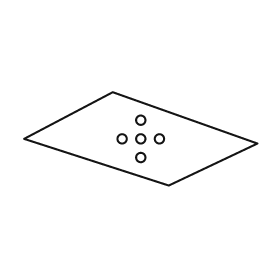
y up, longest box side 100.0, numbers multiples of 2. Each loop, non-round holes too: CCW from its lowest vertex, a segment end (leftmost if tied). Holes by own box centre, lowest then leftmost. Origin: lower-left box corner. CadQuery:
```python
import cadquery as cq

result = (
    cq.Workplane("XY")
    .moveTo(62.0, 0.0)
    .lineTo(100.0, 18.0)
    .lineTo(38.0, 40.0)
    .lineTo(0.0, 20.0)
    .close()
    .moveTo(50.0, 12.0)
    .circle(2.0)
    .moveTo(42.0, 20.0)
    .circle(2.0)
    .moveTo(50.0, 20.0)
    .circle(2.0)
    .moveTo(58.0, 20.0)
    .circle(2.0)
    .moveTo(50.0, 28.0)
    .circle(2.0)
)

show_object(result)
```